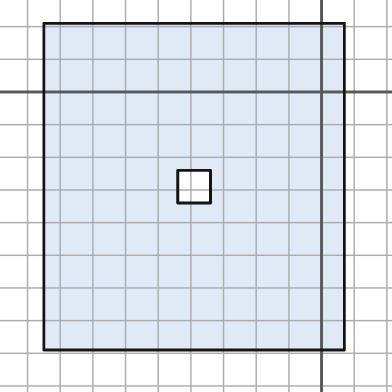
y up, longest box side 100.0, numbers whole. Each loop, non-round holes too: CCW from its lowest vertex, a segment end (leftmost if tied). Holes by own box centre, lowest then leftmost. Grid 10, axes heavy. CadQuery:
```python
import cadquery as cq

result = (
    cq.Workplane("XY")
    .moveTo(-85.0, -79.0)
    .lineTo(7.0, -79.0)
    .lineTo(7.0, 21.0)
    .lineTo(-85.0, 21.0)
    .close()
    .moveTo(-44.0, -34.0)
    .lineTo(-34.0, -34.0)
    .lineTo(-34.0, -24.0)
    .lineTo(-44.0, -24.0)
    .close()
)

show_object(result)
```